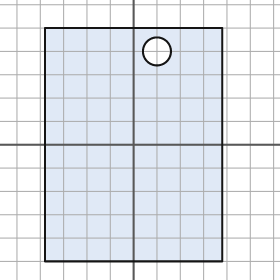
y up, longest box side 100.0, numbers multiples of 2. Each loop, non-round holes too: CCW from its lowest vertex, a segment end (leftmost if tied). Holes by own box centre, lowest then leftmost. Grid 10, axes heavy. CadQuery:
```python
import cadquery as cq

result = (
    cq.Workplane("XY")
    .moveTo(-38.0, -50.0)
    .lineTo(38.0, -50.0)
    .lineTo(38.0, 50.0)
    .lineTo(-38.0, 50.0)
    .close()
    .moveTo(10.0, 40.0)
    .circle(6.0)
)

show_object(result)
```